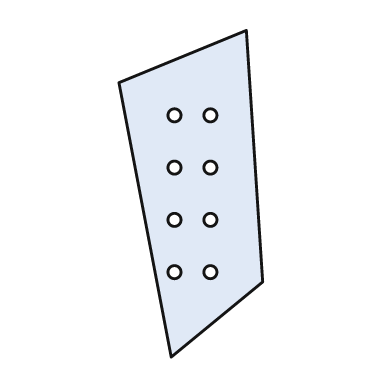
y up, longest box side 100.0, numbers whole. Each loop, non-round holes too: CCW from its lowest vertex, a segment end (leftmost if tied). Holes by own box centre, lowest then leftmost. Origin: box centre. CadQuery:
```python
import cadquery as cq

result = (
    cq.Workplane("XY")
    .moveTo(-6.0, -50.0)
    .lineTo(22.0, -27.0)
    .lineTo(17.0, 50.0)
    .lineTo(-22.0, 34.0)
    .close()
    .moveTo(-5.0, -24.0)
    .circle(2.0)
    .moveTo(6.0, -24.0)
    .circle(2.0)
    .moveTo(-5.0, -8.0)
    .circle(2.0)
    .moveTo(6.0, -8.0)
    .circle(2.0)
    .moveTo(-5.0, 8.0)
    .circle(2.0)
    .moveTo(6.0, 8.0)
    .circle(2.0)
    .moveTo(-5.0, 24.0)
    .circle(2.0)
    .moveTo(6.0, 24.0)
    .circle(2.0)
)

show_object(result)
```